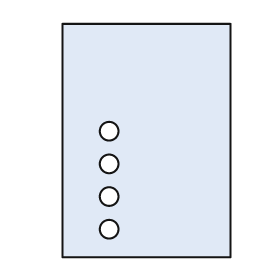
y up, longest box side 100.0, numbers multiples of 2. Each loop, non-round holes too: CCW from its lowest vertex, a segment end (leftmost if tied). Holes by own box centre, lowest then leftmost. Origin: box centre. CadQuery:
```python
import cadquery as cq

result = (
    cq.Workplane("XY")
    .moveTo(-36.0, -50.0)
    .lineTo(36.0, -50.0)
    .lineTo(36.0, 50.0)
    .lineTo(-36.0, 50.0)
    .close()
    .moveTo(-16.0, -38.0)
    .circle(4.0)
    .moveTo(-16.0, -24.0)
    .circle(4.0)
    .moveTo(-16.0, -10.0)
    .circle(4.0)
    .moveTo(-16.0, 4.0)
    .circle(4.0)
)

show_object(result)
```